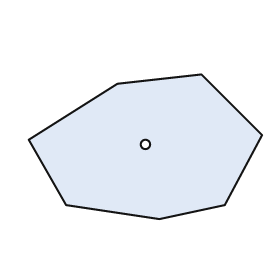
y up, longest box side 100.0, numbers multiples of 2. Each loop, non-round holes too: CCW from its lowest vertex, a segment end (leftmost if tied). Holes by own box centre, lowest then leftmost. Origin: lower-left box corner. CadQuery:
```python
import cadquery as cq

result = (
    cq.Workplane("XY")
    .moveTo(56.0, 0.0)
    .lineTo(84.0, 6.0)
    .lineTo(100.0, 36.0)
    .lineTo(74.0, 62.0)
    .lineTo(38.0, 58.0)
    .lineTo(0.0, 34.0)
    .lineTo(16.0, 6.0)
    .close()
    .moveTo(50.0, 32.0)
    .circle(2.0)
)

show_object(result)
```